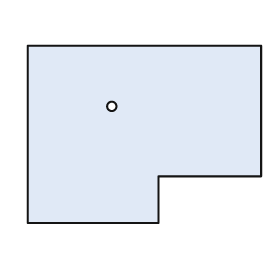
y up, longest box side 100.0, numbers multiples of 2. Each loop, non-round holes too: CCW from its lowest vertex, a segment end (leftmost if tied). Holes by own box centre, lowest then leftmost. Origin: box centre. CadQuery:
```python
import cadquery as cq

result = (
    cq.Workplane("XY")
    .moveTo(-50.0, -38.0)
    .lineTo(6.0, -38.0)
    .lineTo(6.0, -18.0)
    .lineTo(50.0, -18.0)
    .lineTo(50.0, 38.0)
    .lineTo(-50.0, 38.0)
    .close()
    .moveTo(-14.0, 12.0)
    .circle(2.0)
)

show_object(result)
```